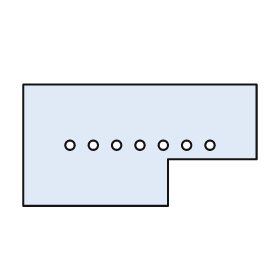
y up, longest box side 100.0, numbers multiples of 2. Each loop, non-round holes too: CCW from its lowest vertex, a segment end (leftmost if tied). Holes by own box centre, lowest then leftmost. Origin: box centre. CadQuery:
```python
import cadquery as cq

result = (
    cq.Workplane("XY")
    .moveTo(-50.0, -26.0)
    .lineTo(12.0, -26.0)
    .lineTo(12.0, -6.0)
    .lineTo(50.0, -6.0)
    .lineTo(50.0, 26.0)
    .lineTo(-50.0, 26.0)
    .close()
    .moveTo(-30.0, 0.0)
    .circle(2.0)
    .moveTo(-20.0, 0.0)
    .circle(2.0)
    .moveTo(-10.0, 0.0)
    .circle(2.0)
    .moveTo(0.0, 0.0)
    .circle(2.0)
    .moveTo(10.0, 0.0)
    .circle(2.0)
    .moveTo(20.0, 0.0)
    .circle(2.0)
    .moveTo(30.0, 0.0)
    .circle(2.0)
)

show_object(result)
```